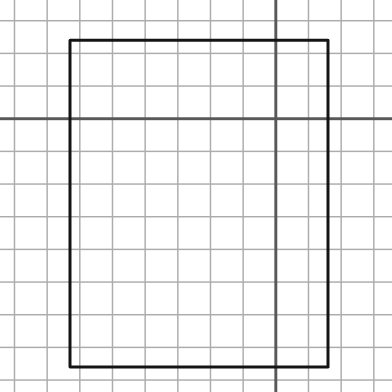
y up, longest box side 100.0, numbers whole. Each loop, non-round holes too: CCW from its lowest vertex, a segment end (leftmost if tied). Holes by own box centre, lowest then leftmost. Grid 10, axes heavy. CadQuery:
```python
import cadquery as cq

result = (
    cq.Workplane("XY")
    .moveTo(-63.0, -76.0)
    .lineTo(16.0, -76.0)
    .lineTo(16.0, 24.0)
    .lineTo(-63.0, 24.0)
    .close()
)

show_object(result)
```